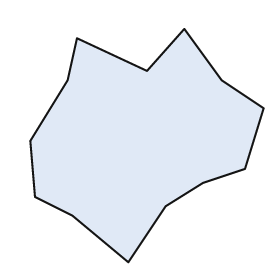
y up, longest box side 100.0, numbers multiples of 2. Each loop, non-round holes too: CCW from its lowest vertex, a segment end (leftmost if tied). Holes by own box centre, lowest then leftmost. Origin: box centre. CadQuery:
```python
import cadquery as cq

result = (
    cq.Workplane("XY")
    .moveTo(-8.0, -50.0)
    .lineTo(8.0, -26.0)
    .lineTo(24.0, -16.0)
    .lineTo(42.0, -10.0)
    .lineTo(50.0, 16.0)
    .lineTo(32.0, 28.0)
    .lineTo(16.0, 50.0)
    .lineTo(0.0, 32.0)
    .lineTo(-30.0, 46.0)
    .lineTo(-34.0, 28.0)
    .lineTo(-50.0, 2.0)
    .lineTo(-48.0, -22.0)
    .lineTo(-32.0, -30.0)
    .close()
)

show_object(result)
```